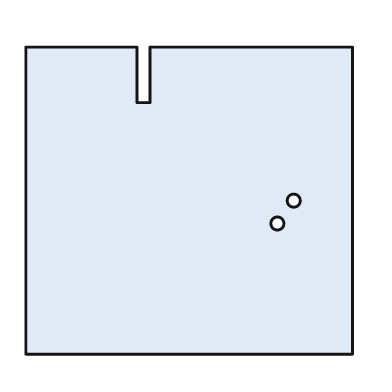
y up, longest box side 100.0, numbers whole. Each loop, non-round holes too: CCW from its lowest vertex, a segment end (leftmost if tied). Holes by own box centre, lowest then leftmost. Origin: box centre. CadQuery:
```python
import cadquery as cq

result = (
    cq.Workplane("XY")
    .moveTo(-50.0, -47.0)
    .lineTo(50.0, -47.0)
    .lineTo(50.0, 47.0)
    .lineTo(-12.0, 47.0)
    .lineTo(-12.0, 30.0)
    .lineTo(-16.0, 30.0)
    .lineTo(-16.0, 47.0)
    .lineTo(-50.0, 47.0)
    .close()
    .moveTo(27.0, -7.0)
    .circle(2.0)
    .moveTo(32.0, 0.0)
    .circle(2.0)
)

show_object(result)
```